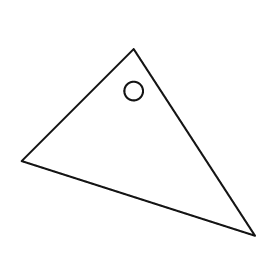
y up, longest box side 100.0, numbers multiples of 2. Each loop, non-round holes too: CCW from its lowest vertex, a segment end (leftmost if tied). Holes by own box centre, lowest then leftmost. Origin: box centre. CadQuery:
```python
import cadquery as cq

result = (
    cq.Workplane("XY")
    .moveTo(50.0, -40.0)
    .lineTo(-2.0, 40.0)
    .lineTo(-50.0, -8.0)
    .close()
    .moveTo(-2.0, 22.0)
    .circle(4.0)
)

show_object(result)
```